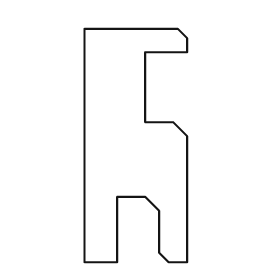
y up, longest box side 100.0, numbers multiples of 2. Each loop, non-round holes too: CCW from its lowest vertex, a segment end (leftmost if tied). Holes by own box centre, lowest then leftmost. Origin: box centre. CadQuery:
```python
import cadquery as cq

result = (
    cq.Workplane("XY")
    .moveTo(-22.0, -50.0)
    .lineTo(-8.0, -50.0)
    .lineTo(-8.0, -22.0)
    .lineTo(4.0, -22.0)
    .lineTo(10.0, -28.0)
    .lineTo(10.0, -46.0)
    .lineTo(14.0, -50.0)
    .lineTo(22.0, -50.0)
    .lineTo(22.0, 4.0)
    .lineTo(16.0, 10.0)
    .lineTo(4.0, 10.0)
    .lineTo(4.0, 40.0)
    .lineTo(22.0, 40.0)
    .lineTo(22.0, 46.0)
    .lineTo(18.0, 50.0)
    .lineTo(-22.0, 50.0)
    .close()
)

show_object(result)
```